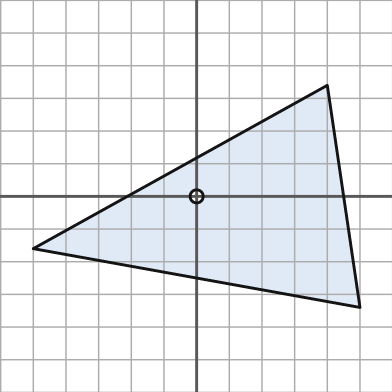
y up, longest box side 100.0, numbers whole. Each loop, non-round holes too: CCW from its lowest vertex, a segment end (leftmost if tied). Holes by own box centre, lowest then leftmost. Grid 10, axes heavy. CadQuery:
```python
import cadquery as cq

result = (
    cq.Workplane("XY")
    .moveTo(50.0, -34.0)
    .lineTo(40.0, 34.0)
    .lineTo(-50.0, -16.0)
    .close()
    .moveTo(0.0, 0.0)
    .circle(2.0)
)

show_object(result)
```